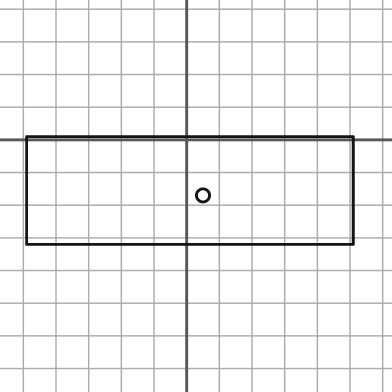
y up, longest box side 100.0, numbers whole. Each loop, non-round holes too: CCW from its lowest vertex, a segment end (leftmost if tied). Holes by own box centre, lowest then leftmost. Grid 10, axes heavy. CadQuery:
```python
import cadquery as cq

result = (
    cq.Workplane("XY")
    .moveTo(-49.0, -32.0)
    .lineTo(51.0, -32.0)
    .lineTo(51.0, 1.0)
    .lineTo(-49.0, 1.0)
    .close()
    .moveTo(5.0, -17.0)
    .circle(2.0)
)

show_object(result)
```